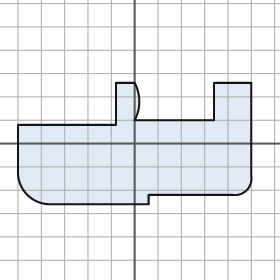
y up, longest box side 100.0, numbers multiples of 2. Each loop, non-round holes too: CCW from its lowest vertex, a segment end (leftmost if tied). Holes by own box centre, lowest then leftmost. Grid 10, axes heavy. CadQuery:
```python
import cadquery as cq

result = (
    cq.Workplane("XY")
    .moveTo(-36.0, -26.0)
    .lineTo(6.0, -26.0)
    .lineTo(6.0, -22.0)
    .lineTo(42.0, -22.0)
    .threePointArc((48.0, -20.0), (50.0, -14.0))
    .lineTo(50.0, 26.0)
    .lineTo(34.0, 26.0)
    .lineTo(34.0, 10.0)
    .lineTo(0.0, 10.0)
    .threePointArc((2.0, 18.0), (0.0, 26.0))
    .lineTo(-8.0, 26.0)
    .lineTo(-8.0, 8.0)
    .lineTo(-50.0, 8.0)
    .lineTo(-50.0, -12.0)
    .threePointArc((-46.0, -22.0), (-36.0, -26.0))
    .close()
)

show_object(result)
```